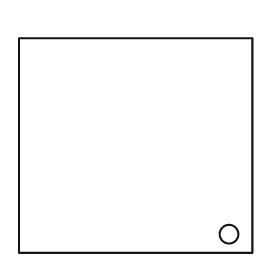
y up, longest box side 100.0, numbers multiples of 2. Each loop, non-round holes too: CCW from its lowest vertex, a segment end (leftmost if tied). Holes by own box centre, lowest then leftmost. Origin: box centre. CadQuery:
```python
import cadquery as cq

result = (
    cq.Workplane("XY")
    .moveTo(-50.0, -46.0)
    .lineTo(50.0, -46.0)
    .lineTo(50.0, 46.0)
    .lineTo(-50.0, 46.0)
    .close()
    .moveTo(40.0, -38.0)
    .circle(4.0)
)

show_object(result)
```